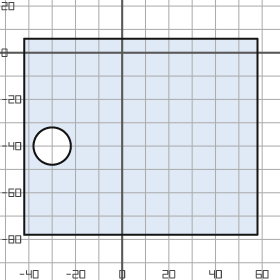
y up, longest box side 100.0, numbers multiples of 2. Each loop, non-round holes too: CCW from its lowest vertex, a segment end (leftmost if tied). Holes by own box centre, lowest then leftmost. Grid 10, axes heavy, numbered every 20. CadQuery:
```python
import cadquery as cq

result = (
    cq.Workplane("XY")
    .moveTo(-42.0, -78.0)
    .lineTo(58.0, -78.0)
    .lineTo(58.0, 6.0)
    .lineTo(-42.0, 6.0)
    .close()
    .moveTo(-30.0, -40.0)
    .circle(8.0)
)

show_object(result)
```